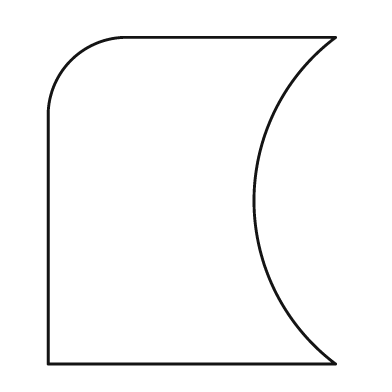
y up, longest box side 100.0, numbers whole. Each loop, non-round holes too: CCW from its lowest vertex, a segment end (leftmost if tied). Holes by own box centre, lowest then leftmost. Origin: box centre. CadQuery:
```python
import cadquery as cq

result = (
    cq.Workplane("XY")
    .moveTo(-44.0, -50.0)
    .lineTo(44.0, -50.0)
    .threePointArc((19.0, 0.0), (44.0, 50.0))
    .lineTo(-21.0, 50.0)
    .threePointArc((-37.0, 43.0), (-44.0, 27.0))
    .close()
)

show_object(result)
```